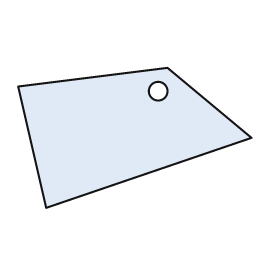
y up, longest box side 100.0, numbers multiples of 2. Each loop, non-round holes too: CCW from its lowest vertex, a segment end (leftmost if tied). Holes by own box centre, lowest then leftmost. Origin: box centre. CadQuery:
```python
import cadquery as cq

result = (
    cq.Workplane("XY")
    .moveTo(-38.0, -30.0)
    .lineTo(50.0, 0.0)
    .lineTo(14.0, 30.0)
    .lineTo(-50.0, 22.0)
    .close()
    .moveTo(10.0, 20.0)
    .circle(4.0)
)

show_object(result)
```